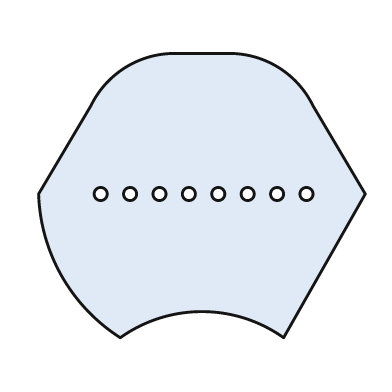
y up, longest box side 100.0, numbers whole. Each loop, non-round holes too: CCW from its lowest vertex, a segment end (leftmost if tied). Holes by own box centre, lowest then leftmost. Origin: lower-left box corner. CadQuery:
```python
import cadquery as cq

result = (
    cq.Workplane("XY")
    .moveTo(25.0, 0.0)
    .threePointArc((50.0, 8.0), (75.0, 0.0))
    .lineTo(100.0, 44.0)
    .lineTo(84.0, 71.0)
    .threePointArc((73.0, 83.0), (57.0, 87.0))
    .lineTo(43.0, 87.0)
    .threePointArc((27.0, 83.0), (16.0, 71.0))
    .lineTo(0.0, 44.0)
    .threePointArc((7.0, 19.0), (25.0, 0.0))
    .close()
    .moveTo(19.0, 44.0)
    .circle(2.0)
    .moveTo(28.0, 44.0)
    .circle(2.0)
    .moveTo(37.0, 44.0)
    .circle(2.0)
    .moveTo(46.0, 44.0)
    .circle(2.0)
    .moveTo(55.0, 44.0)
    .circle(2.0)
    .moveTo(64.0, 44.0)
    .circle(2.0)
    .moveTo(73.0, 44.0)
    .circle(2.0)
    .moveTo(82.0, 44.0)
    .circle(2.0)
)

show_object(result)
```